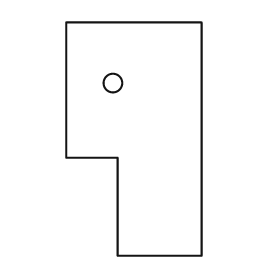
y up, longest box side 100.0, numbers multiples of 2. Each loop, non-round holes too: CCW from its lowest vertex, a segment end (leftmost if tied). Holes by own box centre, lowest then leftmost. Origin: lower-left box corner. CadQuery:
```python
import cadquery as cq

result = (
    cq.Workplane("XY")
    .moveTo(22.0, 0.0)
    .lineTo(58.0, 0.0)
    .lineTo(58.0, 100.0)
    .lineTo(0.0, 100.0)
    .lineTo(0.0, 42.0)
    .lineTo(22.0, 42.0)
    .close()
    .moveTo(20.0, 74.0)
    .circle(4.0)
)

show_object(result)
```